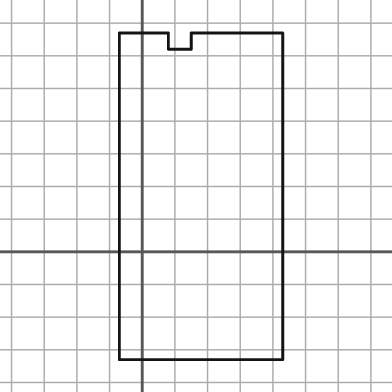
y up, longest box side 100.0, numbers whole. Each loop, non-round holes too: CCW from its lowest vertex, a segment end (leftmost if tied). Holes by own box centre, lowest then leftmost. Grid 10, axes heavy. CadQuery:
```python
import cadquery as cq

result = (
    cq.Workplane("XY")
    .moveTo(-7.0, -33.0)
    .lineTo(43.0, -33.0)
    .lineTo(43.0, 67.0)
    .lineTo(15.0, 67.0)
    .lineTo(15.0, 62.0)
    .lineTo(8.0, 62.0)
    .lineTo(8.0, 67.0)
    .lineTo(-7.0, 67.0)
    .close()
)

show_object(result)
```